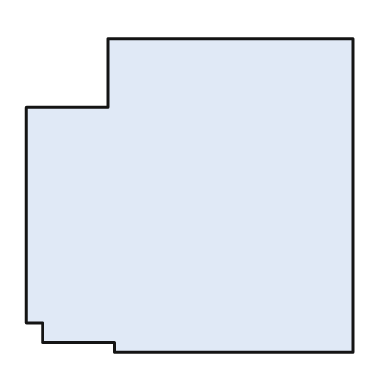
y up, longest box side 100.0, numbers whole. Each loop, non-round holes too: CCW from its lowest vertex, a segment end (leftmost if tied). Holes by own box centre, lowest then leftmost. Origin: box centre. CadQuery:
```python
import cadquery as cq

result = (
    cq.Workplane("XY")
    .moveTo(-23.0, -48.0)
    .lineTo(50.0, -48.0)
    .lineTo(50.0, 48.0)
    .lineTo(-25.0, 48.0)
    .lineTo(-25.0, 27.0)
    .lineTo(-50.0, 27.0)
    .lineTo(-50.0, -39.0)
    .lineTo(-45.0, -39.0)
    .lineTo(-45.0, -45.0)
    .lineTo(-23.0, -45.0)
    .close()
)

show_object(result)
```